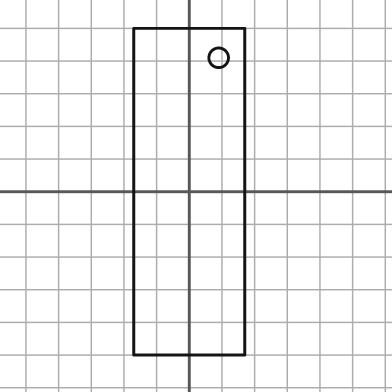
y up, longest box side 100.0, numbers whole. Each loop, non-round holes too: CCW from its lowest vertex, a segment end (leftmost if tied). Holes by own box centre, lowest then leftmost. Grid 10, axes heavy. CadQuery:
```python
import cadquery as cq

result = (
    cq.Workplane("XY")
    .moveTo(-17.0, -50.0)
    .lineTo(17.0, -50.0)
    .lineTo(17.0, 50.0)
    .lineTo(-17.0, 50.0)
    .close()
    .moveTo(9.0, 41.0)
    .circle(3.0)
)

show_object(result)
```